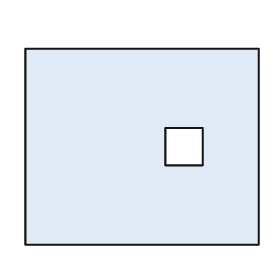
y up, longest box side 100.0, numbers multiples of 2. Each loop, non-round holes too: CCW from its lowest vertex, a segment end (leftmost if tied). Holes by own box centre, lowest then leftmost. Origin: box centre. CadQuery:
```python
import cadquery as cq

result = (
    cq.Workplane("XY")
    .moveTo(-50.0, -42.0)
    .lineTo(50.0, -42.0)
    .lineTo(50.0, 42.0)
    .lineTo(-50.0, 42.0)
    .close()
    .moveTo(10.0, -8.0)
    .lineTo(26.0, -8.0)
    .lineTo(26.0, 8.0)
    .lineTo(10.0, 8.0)
    .close()
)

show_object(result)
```